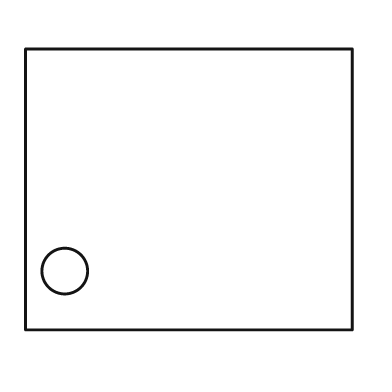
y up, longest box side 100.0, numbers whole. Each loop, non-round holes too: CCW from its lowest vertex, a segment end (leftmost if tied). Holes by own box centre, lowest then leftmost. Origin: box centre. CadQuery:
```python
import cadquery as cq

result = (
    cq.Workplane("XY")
    .moveTo(-50.0, -43.0)
    .lineTo(50.0, -43.0)
    .lineTo(50.0, 43.0)
    .lineTo(-50.0, 43.0)
    .close()
    .moveTo(-38.0, -25.0)
    .circle(7.0)
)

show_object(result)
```